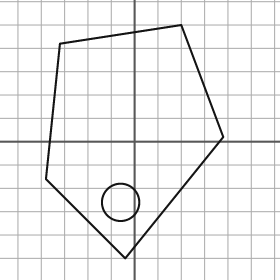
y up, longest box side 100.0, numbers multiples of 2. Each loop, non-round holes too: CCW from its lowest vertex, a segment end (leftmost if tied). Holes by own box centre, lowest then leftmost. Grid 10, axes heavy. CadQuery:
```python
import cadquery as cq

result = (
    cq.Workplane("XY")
    .moveTo(-4.0, -50.0)
    .lineTo(38.0, 2.0)
    .lineTo(20.0, 50.0)
    .lineTo(-32.0, 42.0)
    .lineTo(-38.0, -16.0)
    .close()
    .moveTo(-6.0, -26.0)
    .circle(8.0)
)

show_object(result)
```